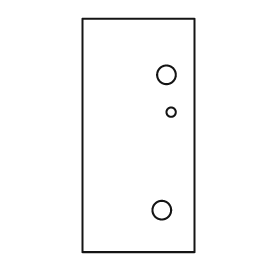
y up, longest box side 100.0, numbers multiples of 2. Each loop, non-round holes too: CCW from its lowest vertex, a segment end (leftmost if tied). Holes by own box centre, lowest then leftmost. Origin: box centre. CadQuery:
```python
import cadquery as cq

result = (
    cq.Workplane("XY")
    .moveTo(-24.0, -50.0)
    .lineTo(24.0, -50.0)
    .lineTo(24.0, 50.0)
    .lineTo(-24.0, 50.0)
    .close()
    .moveTo(10.0, -32.0)
    .circle(4.0)
    .moveTo(14.0, 10.0)
    .circle(2.0)
    .moveTo(12.0, 26.0)
    .circle(4.0)
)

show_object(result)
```